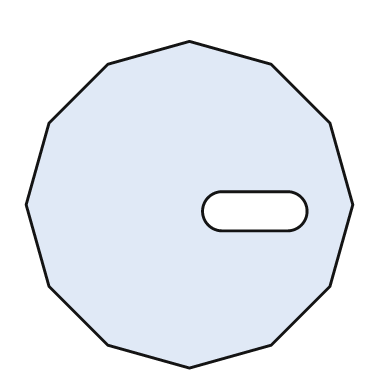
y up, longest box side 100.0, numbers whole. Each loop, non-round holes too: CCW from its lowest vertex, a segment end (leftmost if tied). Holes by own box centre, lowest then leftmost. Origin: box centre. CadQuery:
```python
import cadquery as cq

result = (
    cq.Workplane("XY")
    .moveTo(0.0, -50.0)
    .lineTo(25.0, -43.0)
    .lineTo(43.0, -25.0)
    .lineTo(50.0, 0.0)
    .lineTo(43.0, 25.0)
    .lineTo(25.0, 43.0)
    .lineTo(0.0, 50.0)
    .lineTo(-25.0, 43.0)
    .lineTo(-43.0, 25.0)
    .lineTo(-50.0, 0.0)
    .lineTo(-43.0, -25.0)
    .lineTo(-25.0, -43.0)
    .close()
    .moveTo(10.0, -8.0)
    .lineTo(30.0, -8.0)
    .threePointArc((36.0, -2.0), (30.0, 4.0))
    .lineTo(10.0, 4.0)
    .threePointArc((4.0, -2.0), (10.0, -8.0))
    .close()
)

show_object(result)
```